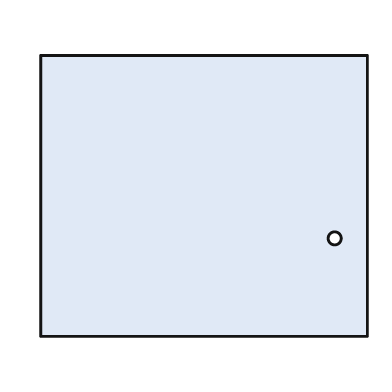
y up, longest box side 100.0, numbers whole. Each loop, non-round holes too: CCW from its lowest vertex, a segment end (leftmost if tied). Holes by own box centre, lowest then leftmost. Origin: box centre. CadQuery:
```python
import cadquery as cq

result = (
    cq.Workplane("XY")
    .moveTo(-50.0, -43.0)
    .lineTo(50.0, -43.0)
    .lineTo(50.0, 43.0)
    .lineTo(-50.0, 43.0)
    .close()
    .moveTo(40.0, -13.0)
    .circle(2.0)
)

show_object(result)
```